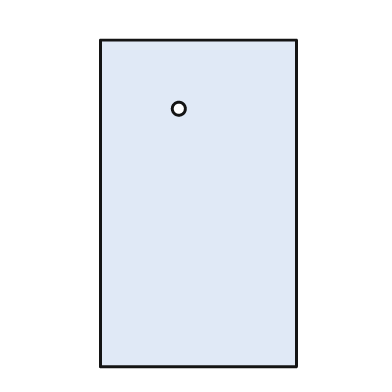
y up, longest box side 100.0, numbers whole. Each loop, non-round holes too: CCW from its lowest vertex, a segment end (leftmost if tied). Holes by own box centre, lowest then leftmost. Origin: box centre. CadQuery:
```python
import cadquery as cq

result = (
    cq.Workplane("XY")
    .moveTo(-30.0, -50.0)
    .lineTo(30.0, -50.0)
    .lineTo(30.0, 50.0)
    .lineTo(-30.0, 50.0)
    .close()
    .moveTo(-6.0, 29.0)
    .circle(2.0)
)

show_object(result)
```